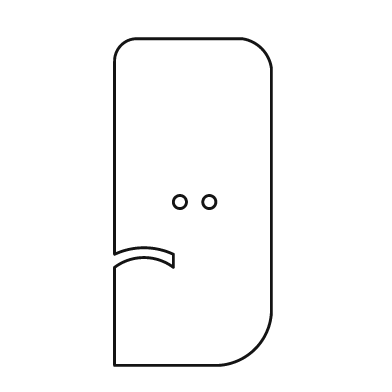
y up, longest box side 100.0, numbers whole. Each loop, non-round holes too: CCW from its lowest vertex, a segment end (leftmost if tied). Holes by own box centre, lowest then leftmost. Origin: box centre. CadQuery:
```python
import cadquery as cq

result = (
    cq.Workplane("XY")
    .moveTo(-24.0, -50.0)
    .lineTo(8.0, -50.0)
    .threePointArc((19.0, -45.0), (24.0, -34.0))
    .lineTo(24.0, 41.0)
    .threePointArc((21.0, 47.0), (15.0, 50.0))
    .lineTo(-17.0, 50.0)
    .threePointArc((-22.0, 48.0), (-24.0, 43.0))
    .lineTo(-24.0, -16.0)
    .threePointArc((-15.0, -14.0), (-6.0, -16.0))
    .lineTo(-6.0, -20.0)
    .threePointArc((-15.0, -17.0), (-24.0, -20.0))
    .close()
    .moveTo(-4.0, 0.0)
    .circle(2.0)
    .moveTo(5.0, 0.0)
    .circle(2.0)
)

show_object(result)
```